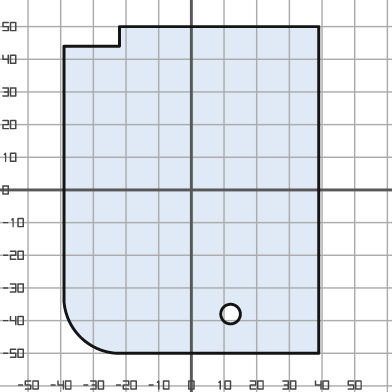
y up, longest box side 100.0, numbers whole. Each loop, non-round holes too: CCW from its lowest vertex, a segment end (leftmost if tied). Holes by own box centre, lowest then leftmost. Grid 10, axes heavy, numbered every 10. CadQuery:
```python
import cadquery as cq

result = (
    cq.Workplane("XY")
    .moveTo(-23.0, -50.0)
    .lineTo(39.0, -50.0)
    .lineTo(39.0, 50.0)
    .lineTo(-22.0, 50.0)
    .lineTo(-22.0, 44.0)
    .lineTo(-39.0, 44.0)
    .lineTo(-39.0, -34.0)
    .threePointArc((-34.0, -45.0), (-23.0, -50.0))
    .close()
    .moveTo(12.0, -38.0)
    .circle(3.0)
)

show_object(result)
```